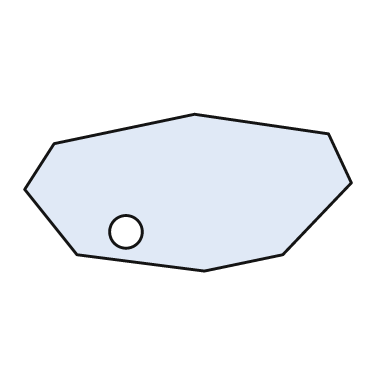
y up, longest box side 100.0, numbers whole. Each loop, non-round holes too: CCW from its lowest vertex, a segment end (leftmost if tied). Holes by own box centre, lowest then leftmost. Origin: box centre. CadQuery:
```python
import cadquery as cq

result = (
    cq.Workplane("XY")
    .moveTo(5.0, -24.0)
    .lineTo(29.0, -19.0)
    .lineTo(50.0, 3.0)
    .lineTo(43.0, 18.0)
    .lineTo(2.0, 24.0)
    .lineTo(-41.0, 15.0)
    .lineTo(-50.0, 1.0)
    .lineTo(-34.0, -19.0)
    .close()
    .moveTo(-19.0, -12.0)
    .circle(5.0)
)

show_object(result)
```